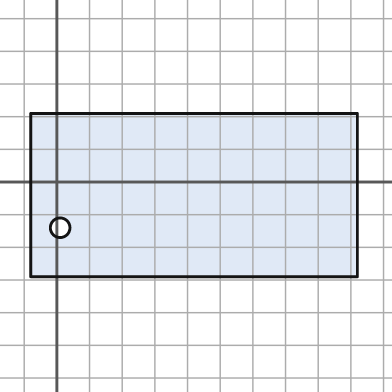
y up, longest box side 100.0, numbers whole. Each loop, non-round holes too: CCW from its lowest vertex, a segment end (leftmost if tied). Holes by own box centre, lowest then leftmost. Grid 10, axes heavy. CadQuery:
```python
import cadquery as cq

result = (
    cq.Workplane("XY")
    .moveTo(-8.0, -29.0)
    .lineTo(92.0, -29.0)
    .lineTo(92.0, 21.0)
    .lineTo(-8.0, 21.0)
    .close()
    .moveTo(1.0, -14.0)
    .circle(3.0)
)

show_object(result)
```